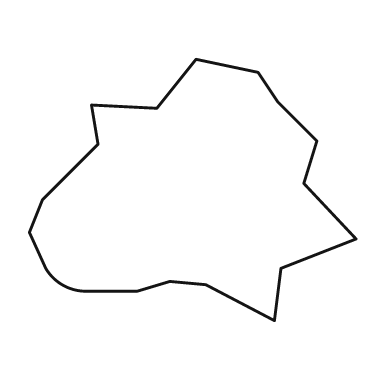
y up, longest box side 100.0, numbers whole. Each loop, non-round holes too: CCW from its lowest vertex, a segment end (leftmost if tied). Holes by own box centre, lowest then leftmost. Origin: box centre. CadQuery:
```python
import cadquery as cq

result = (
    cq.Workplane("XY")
    .moveTo(25.0, -40.0)
    .lineTo(27.0, -24.0)
    .lineTo(50.0, -15.0)
    .lineTo(34.0, 2.0)
    .lineTo(38.0, 15.0)
    .lineTo(26.0, 27.0)
    .lineTo(20.0, 36.0)
    .lineTo(1.0, 40.0)
    .lineTo(-11.0, 25.0)
    .lineTo(-31.0, 26.0)
    .lineTo(-29.0, 14.0)
    .lineTo(-46.0, -3.0)
    .lineTo(-50.0, -13.0)
    .lineTo(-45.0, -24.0)
    .threePointArc((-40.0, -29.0), (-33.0, -31.0))
    .lineTo(-17.0, -31.0)
    .lineTo(-7.0, -28.0)
    .lineTo(4.0, -29.0)
    .close()
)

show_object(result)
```